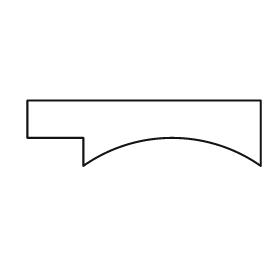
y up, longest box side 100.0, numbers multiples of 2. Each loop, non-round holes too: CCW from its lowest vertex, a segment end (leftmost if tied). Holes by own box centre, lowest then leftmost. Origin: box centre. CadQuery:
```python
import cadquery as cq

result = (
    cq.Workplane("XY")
    .moveTo(-26.0, -14.0)
    .threePointArc((12.0, -2.0), (50.0, -14.0))
    .lineTo(50.0, 14.0)
    .lineTo(-50.0, 14.0)
    .lineTo(-50.0, -2.0)
    .lineTo(-26.0, -2.0)
    .close()
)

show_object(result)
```